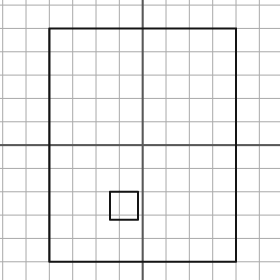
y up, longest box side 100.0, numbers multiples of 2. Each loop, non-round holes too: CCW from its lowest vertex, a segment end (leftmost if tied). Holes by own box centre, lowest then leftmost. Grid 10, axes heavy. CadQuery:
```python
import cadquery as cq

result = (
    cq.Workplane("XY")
    .moveTo(-40.0, -50.0)
    .lineTo(40.0, -50.0)
    .lineTo(40.0, 50.0)
    .lineTo(-40.0, 50.0)
    .close()
    .moveTo(-14.0, -32.0)
    .lineTo(-2.0, -32.0)
    .lineTo(-2.0, -20.0)
    .lineTo(-14.0, -20.0)
    .close()
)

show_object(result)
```